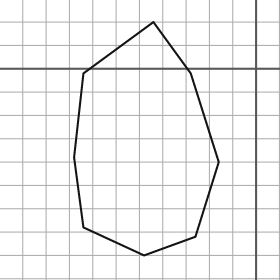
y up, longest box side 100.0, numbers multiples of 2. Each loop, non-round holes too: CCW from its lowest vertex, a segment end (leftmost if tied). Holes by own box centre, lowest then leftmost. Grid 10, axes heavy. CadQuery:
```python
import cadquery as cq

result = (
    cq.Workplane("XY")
    .moveTo(-48.0, -80.0)
    .lineTo(-26.0, -72.0)
    .lineTo(-16.0, -40.0)
    .lineTo(-28.0, -2.0)
    .lineTo(-44.0, 20.0)
    .lineTo(-74.0, -2.0)
    .lineTo(-78.0, -38.0)
    .lineTo(-74.0, -68.0)
    .close()
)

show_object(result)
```